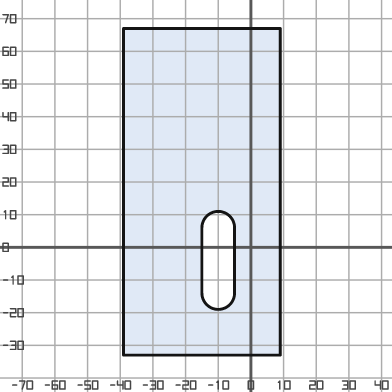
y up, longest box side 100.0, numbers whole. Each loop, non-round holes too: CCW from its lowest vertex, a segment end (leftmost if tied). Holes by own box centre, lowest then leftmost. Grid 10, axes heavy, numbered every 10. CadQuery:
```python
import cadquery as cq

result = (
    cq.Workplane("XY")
    .moveTo(-39.0, -33.0)
    .lineTo(9.0, -33.0)
    .lineTo(9.0, 67.0)
    .lineTo(-39.0, 67.0)
    .close()
    .moveTo(-15.0, -14.0)
    .threePointArc((-10.0, -19.0), (-5.0, -14.0))
    .lineTo(-5.0, 6.0)
    .threePointArc((-10.0, 11.0), (-15.0, 6.0))
    .close()
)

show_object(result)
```